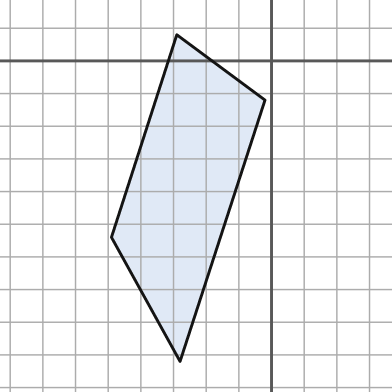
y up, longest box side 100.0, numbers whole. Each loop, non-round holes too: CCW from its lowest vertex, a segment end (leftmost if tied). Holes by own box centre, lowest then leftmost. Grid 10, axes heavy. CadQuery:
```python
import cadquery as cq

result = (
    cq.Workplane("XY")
    .moveTo(-28.0, -92.0)
    .lineTo(-2.0, -12.0)
    .lineTo(-29.0, 8.0)
    .lineTo(-49.0, -54.0)
    .close()
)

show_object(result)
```